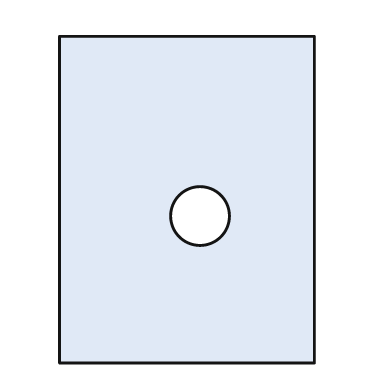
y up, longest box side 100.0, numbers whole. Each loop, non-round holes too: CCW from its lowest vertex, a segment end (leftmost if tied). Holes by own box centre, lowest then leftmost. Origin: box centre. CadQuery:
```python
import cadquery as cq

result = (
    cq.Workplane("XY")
    .moveTo(-39.0, -50.0)
    .lineTo(39.0, -50.0)
    .lineTo(39.0, 50.0)
    .lineTo(-39.0, 50.0)
    .close()
    .moveTo(4.0, -5.0)
    .circle(9.0)
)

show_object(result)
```